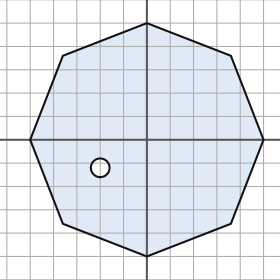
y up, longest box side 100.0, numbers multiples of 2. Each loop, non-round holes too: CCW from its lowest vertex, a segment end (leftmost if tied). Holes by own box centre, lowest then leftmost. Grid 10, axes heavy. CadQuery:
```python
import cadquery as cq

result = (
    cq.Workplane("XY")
    .moveTo(0.0, -50.0)
    .lineTo(36.0, -36.0)
    .lineTo(50.0, 0.0)
    .lineTo(36.0, 36.0)
    .lineTo(0.0, 50.0)
    .lineTo(-36.0, 36.0)
    .lineTo(-50.0, 0.0)
    .lineTo(-36.0, -36.0)
    .close()
    .moveTo(-20.0, -12.0)
    .circle(4.0)
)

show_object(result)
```